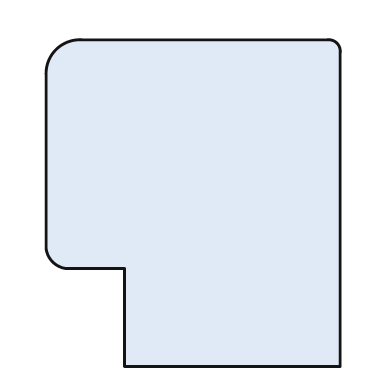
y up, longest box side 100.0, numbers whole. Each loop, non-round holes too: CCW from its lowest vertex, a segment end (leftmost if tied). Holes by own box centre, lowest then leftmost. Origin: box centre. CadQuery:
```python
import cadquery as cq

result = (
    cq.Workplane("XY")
    .moveTo(-21.0, -50.0)
    .lineTo(45.0, -50.0)
    .lineTo(45.0, 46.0)
    .threePointArc((44.0, 49.0), (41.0, 50.0))
    .lineTo(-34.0, 50.0)
    .threePointArc((-42.0, 47.0), (-45.0, 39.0))
    .lineTo(-45.0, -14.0)
    .threePointArc((-43.0, -18.0), (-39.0, -20.0))
    .lineTo(-21.0, -20.0)
    .close()
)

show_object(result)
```